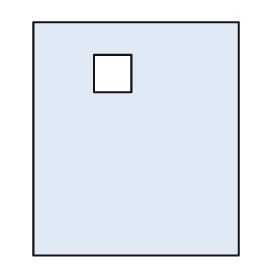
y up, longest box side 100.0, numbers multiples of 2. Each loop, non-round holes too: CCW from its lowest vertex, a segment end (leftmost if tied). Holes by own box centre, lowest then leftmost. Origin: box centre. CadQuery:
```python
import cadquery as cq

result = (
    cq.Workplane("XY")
    .moveTo(-44.0, -50.0)
    .lineTo(44.0, -50.0)
    .lineTo(44.0, 50.0)
    .lineTo(-44.0, 50.0)
    .close()
    .moveTo(-18.0, 20.0)
    .lineTo(-2.0, 20.0)
    .lineTo(-2.0, 36.0)
    .lineTo(-18.0, 36.0)
    .close()
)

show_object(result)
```